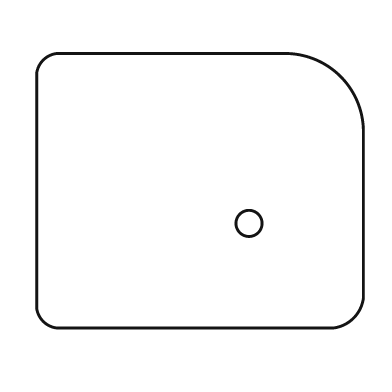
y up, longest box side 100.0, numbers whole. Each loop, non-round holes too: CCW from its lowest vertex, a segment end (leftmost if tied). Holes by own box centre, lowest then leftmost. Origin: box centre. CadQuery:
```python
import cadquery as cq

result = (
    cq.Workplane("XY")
    .moveTo(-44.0, -42.0)
    .lineTo(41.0, -42.0)
    .threePointArc((47.0, -39.0), (50.0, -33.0))
    .lineTo(50.0, 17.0)
    .threePointArc((43.0, 35.0), (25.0, 42.0))
    .lineTo(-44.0, 42.0)
    .threePointArc((-48.0, 40.0), (-50.0, 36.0))
    .lineTo(-50.0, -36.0)
    .threePointArc((-48.0, -40.0), (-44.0, -42.0))
    .close()
    .moveTo(15.0, -10.0)
    .circle(4.0)
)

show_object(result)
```